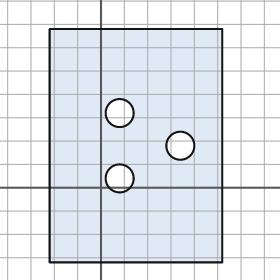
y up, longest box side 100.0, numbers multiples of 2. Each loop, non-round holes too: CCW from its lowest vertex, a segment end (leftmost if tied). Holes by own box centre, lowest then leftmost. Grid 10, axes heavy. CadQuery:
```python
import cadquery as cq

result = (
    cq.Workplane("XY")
    .moveTo(-22.0, -32.0)
    .lineTo(52.0, -32.0)
    .lineTo(52.0, 68.0)
    .lineTo(-22.0, 68.0)
    .close()
    .moveTo(8.0, 4.0)
    .circle(6.0)
    .moveTo(34.0, 18.0)
    .circle(6.0)
    .moveTo(8.0, 32.0)
    .circle(6.0)
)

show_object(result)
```